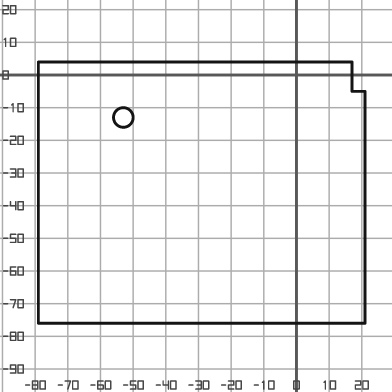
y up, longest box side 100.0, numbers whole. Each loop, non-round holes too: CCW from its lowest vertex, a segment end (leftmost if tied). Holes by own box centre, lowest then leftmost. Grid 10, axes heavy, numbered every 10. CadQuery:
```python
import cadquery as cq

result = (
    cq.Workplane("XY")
    .moveTo(-79.0, -76.0)
    .lineTo(21.0, -76.0)
    .lineTo(21.0, -5.0)
    .lineTo(17.0, -5.0)
    .lineTo(17.0, 4.0)
    .lineTo(-79.0, 4.0)
    .close()
    .moveTo(-53.0, -13.0)
    .circle(3.0)
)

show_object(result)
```